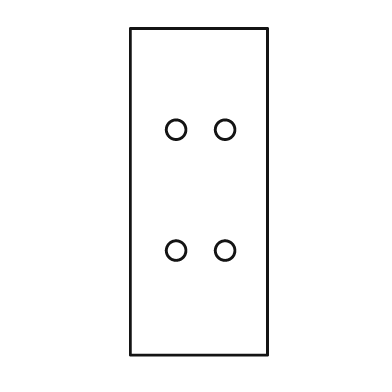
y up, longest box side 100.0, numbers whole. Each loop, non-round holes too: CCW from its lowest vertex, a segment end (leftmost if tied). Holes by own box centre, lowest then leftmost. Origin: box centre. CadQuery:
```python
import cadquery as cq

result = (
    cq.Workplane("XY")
    .moveTo(-21.0, -50.0)
    .lineTo(21.0, -50.0)
    .lineTo(21.0, 50.0)
    .lineTo(-21.0, 50.0)
    .close()
    .moveTo(-7.0, -18.0)
    .circle(3.0)
    .moveTo(8.0, -18.0)
    .circle(3.0)
    .moveTo(-7.0, 19.0)
    .circle(3.0)
    .moveTo(8.0, 19.0)
    .circle(3.0)
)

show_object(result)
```